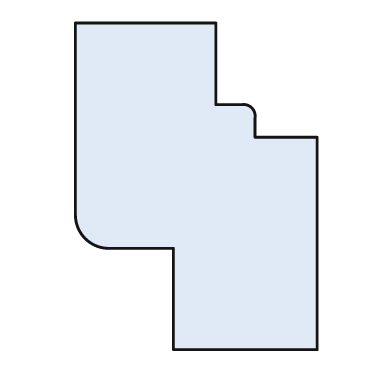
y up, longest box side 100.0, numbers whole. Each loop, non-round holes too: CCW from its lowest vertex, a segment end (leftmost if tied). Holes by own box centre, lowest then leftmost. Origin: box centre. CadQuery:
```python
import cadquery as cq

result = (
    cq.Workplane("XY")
    .moveTo(-7.0, -50.0)
    .lineTo(37.0, -50.0)
    .lineTo(37.0, 15.0)
    .lineTo(18.0, 15.0)
    .lineTo(18.0, 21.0)
    .threePointArc((17.0, 24.0), (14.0, 25.0))
    .lineTo(6.0, 25.0)
    .lineTo(6.0, 50.0)
    .lineTo(-37.0, 50.0)
    .lineTo(-37.0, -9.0)
    .threePointArc((-34.0, -16.0), (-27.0, -19.0))
    .lineTo(-7.0, -19.0)
    .close()
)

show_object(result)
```